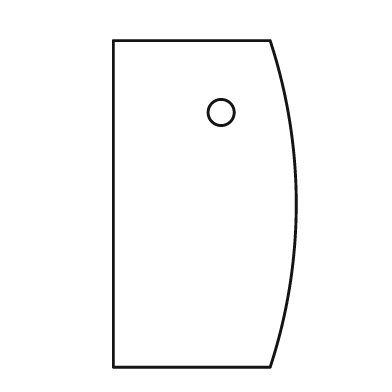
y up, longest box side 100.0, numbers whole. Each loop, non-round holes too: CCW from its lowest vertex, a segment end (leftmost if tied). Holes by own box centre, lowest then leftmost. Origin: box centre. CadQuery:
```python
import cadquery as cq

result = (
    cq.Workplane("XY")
    .moveTo(-28.0, -50.0)
    .lineTo(20.0, -50.0)
    .threePointArc((28.0, 0.0), (20.0, 50.0))
    .lineTo(-28.0, 50.0)
    .close()
    .moveTo(5.0, 28.0)
    .circle(4.0)
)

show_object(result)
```